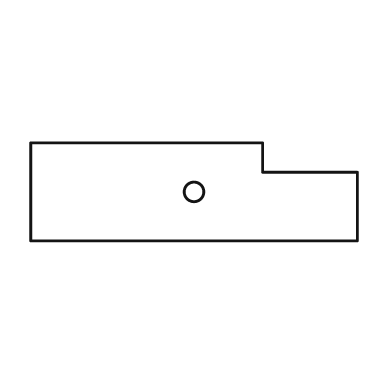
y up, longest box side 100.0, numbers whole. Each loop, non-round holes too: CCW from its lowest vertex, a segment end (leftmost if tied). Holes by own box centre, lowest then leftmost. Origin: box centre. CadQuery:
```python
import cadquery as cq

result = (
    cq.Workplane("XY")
    .moveTo(-50.0, -15.0)
    .lineTo(50.0, -15.0)
    .lineTo(50.0, 6.0)
    .lineTo(21.0, 6.0)
    .lineTo(21.0, 15.0)
    .lineTo(-50.0, 15.0)
    .close()
    .moveTo(0.0, 0.0)
    .circle(3.0)
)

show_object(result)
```